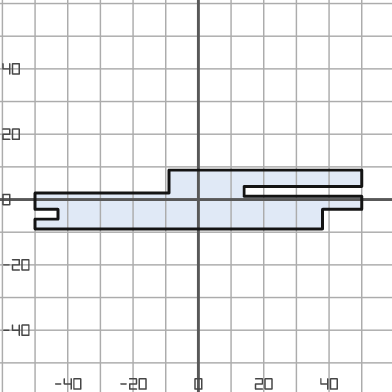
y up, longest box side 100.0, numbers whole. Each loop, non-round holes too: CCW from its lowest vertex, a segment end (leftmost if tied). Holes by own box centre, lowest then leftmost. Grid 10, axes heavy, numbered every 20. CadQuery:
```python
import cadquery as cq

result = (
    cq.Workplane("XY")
    .moveTo(-50.0, -9.0)
    .lineTo(38.0, -9.0)
    .lineTo(38.0, -3.0)
    .lineTo(50.0, -3.0)
    .lineTo(50.0, 1.0)
    .lineTo(14.0, 1.0)
    .lineTo(14.0, 4.0)
    .lineTo(50.0, 4.0)
    .lineTo(50.0, 9.0)
    .lineTo(-9.0, 9.0)
    .lineTo(-9.0, 2.0)
    .lineTo(-50.0, 2.0)
    .lineTo(-50.0, -3.0)
    .lineTo(-43.0, -3.0)
    .lineTo(-43.0, -6.0)
    .lineTo(-50.0, -6.0)
    .close()
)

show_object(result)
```